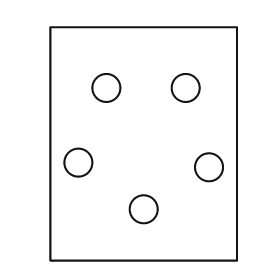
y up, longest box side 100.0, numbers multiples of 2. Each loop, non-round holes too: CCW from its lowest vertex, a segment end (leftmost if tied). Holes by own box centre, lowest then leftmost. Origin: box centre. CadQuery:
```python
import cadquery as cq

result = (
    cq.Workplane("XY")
    .moveTo(-40.0, -50.0)
    .lineTo(40.0, -50.0)
    .lineTo(40.0, 50.0)
    .lineTo(-40.0, 50.0)
    .close()
    .moveTo(0.0, -28.0)
    .circle(6.0)
    .moveTo(28.0, -10.0)
    .circle(6.0)
    .moveTo(-28.0, -8.0)
    .circle(6.0)
    .moveTo(-16.0, 24.0)
    .circle(6.0)
    .moveTo(18.0, 24.0)
    .circle(6.0)
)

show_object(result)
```